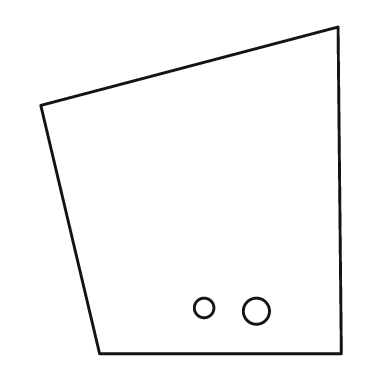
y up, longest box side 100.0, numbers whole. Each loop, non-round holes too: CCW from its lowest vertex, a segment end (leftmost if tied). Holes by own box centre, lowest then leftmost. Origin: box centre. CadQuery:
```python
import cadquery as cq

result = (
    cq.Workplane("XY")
    .moveTo(-28.0, -50.0)
    .lineTo(46.0, -50.0)
    .lineTo(45.0, 50.0)
    .lineTo(-46.0, 26.0)
    .close()
    .moveTo(20.0, -37.0)
    .circle(4.0)
    .moveTo(4.0, -36.0)
    .circle(3.0)
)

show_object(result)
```